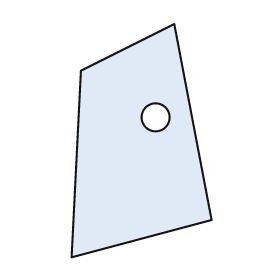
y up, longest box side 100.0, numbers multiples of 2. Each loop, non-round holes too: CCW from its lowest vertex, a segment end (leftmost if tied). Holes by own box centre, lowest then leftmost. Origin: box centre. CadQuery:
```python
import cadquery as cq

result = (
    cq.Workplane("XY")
    .moveTo(-30.0, -50.0)
    .lineTo(30.0, -34.0)
    .lineTo(14.0, 50.0)
    .lineTo(-26.0, 30.0)
    .close()
    .moveTo(6.0, 10.0)
    .circle(6.0)
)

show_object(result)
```